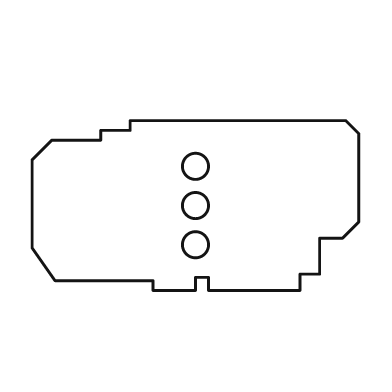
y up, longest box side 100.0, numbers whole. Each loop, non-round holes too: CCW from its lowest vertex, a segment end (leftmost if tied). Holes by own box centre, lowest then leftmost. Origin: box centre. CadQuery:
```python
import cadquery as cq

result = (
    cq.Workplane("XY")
    .moveTo(-13.0, -26.0)
    .lineTo(0.0, -26.0)
    .lineTo(0.0, -22.0)
    .lineTo(4.0, -22.0)
    .lineTo(4.0, -26.0)
    .lineTo(32.0, -26.0)
    .lineTo(32.0, -21.0)
    .lineTo(38.0, -21.0)
    .lineTo(38.0, -10.0)
    .lineTo(45.0, -10.0)
    .lineTo(50.0, -5.0)
    .lineTo(50.0, 22.0)
    .lineTo(46.0, 26.0)
    .lineTo(-20.0, 26.0)
    .lineTo(-20.0, 23.0)
    .lineTo(-29.0, 23.0)
    .lineTo(-29.0, 20.0)
    .lineTo(-44.0, 20.0)
    .lineTo(-50.0, 14.0)
    .lineTo(-50.0, -13.0)
    .lineTo(-43.0, -23.0)
    .lineTo(-13.0, -23.0)
    .close()
    .moveTo(0.0, -12.0)
    .circle(4.0)
    .moveTo(0.0, 0.0)
    .circle(4.0)
    .moveTo(0.0, 12.0)
    .circle(4.0)
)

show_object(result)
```